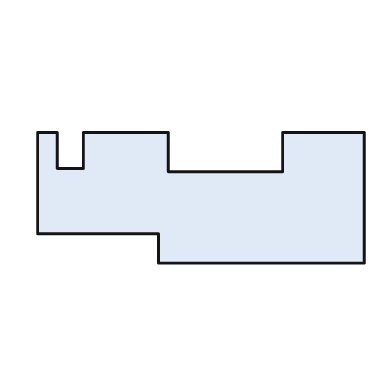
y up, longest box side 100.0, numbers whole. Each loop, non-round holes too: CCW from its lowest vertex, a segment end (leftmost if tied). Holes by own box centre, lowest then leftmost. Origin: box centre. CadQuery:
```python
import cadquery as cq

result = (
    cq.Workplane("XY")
    .moveTo(-13.0, -20.0)
    .lineTo(50.0, -20.0)
    .lineTo(50.0, 20.0)
    .lineTo(25.0, 20.0)
    .lineTo(25.0, 8.0)
    .lineTo(-10.0, 8.0)
    .lineTo(-10.0, 20.0)
    .lineTo(-36.0, 20.0)
    .lineTo(-36.0, 9.0)
    .lineTo(-44.0, 9.0)
    .lineTo(-44.0, 20.0)
    .lineTo(-50.0, 20.0)
    .lineTo(-50.0, -11.0)
    .lineTo(-13.0, -11.0)
    .close()
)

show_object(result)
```